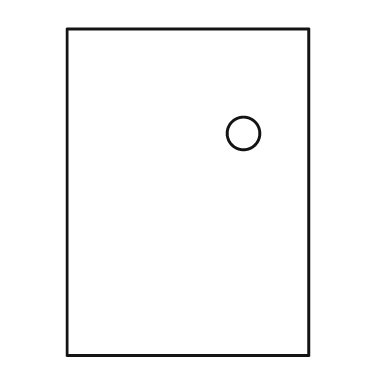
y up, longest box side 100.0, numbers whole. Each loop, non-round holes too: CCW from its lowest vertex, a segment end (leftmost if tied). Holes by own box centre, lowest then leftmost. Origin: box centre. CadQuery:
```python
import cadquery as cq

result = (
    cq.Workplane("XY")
    .moveTo(-37.0, -50.0)
    .lineTo(37.0, -50.0)
    .lineTo(37.0, 50.0)
    .lineTo(-37.0, 50.0)
    .close()
    .moveTo(17.0, 18.0)
    .circle(5.0)
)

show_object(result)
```